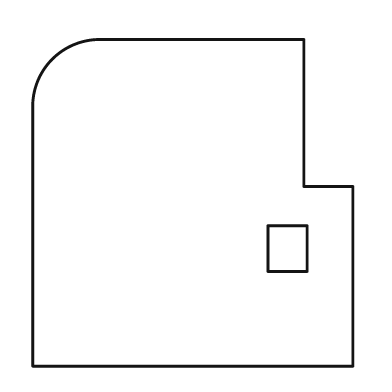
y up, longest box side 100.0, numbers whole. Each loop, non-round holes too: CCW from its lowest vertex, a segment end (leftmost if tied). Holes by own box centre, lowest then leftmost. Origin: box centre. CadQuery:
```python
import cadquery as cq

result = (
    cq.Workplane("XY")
    .moveTo(-49.0, -50.0)
    .lineTo(49.0, -50.0)
    .lineTo(49.0, 5.0)
    .lineTo(34.0, 5.0)
    .lineTo(34.0, 50.0)
    .lineTo(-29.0, 50.0)
    .threePointArc((-43.0, 44.0), (-49.0, 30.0))
    .close()
    .moveTo(23.0, -21.0)
    .lineTo(35.0, -21.0)
    .lineTo(35.0, -7.0)
    .lineTo(23.0, -7.0)
    .close()
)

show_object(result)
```